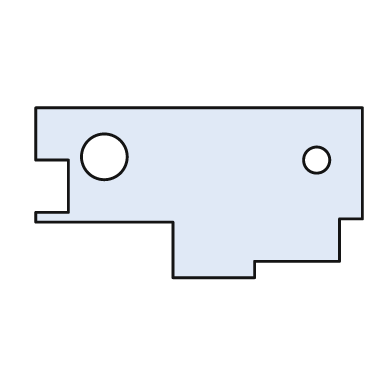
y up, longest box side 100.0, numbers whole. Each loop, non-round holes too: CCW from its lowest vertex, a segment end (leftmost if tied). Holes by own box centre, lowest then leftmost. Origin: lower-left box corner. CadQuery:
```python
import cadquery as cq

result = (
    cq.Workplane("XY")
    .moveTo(42.0, 0.0)
    .lineTo(67.0, 0.0)
    .lineTo(67.0, 5.0)
    .lineTo(93.0, 5.0)
    .lineTo(93.0, 18.0)
    .lineTo(100.0, 18.0)
    .lineTo(100.0, 52.0)
    .lineTo(0.0, 52.0)
    .lineTo(0.0, 36.0)
    .lineTo(10.0, 36.0)
    .lineTo(10.0, 20.0)
    .lineTo(0.0, 20.0)
    .lineTo(0.0, 17.0)
    .lineTo(42.0, 17.0)
    .close()
    .moveTo(86.0, 36.0)
    .circle(4.0)
    .moveTo(21.0, 37.0)
    .circle(7.0)
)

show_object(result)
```